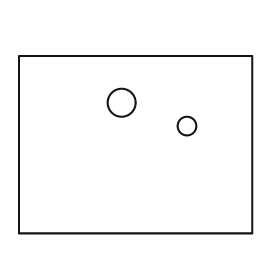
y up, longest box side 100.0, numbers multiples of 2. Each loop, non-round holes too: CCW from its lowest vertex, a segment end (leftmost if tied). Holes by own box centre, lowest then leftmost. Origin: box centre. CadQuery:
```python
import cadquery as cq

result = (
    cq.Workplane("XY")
    .moveTo(-50.0, -38.0)
    .lineTo(50.0, -38.0)
    .lineTo(50.0, 38.0)
    .lineTo(-50.0, 38.0)
    .close()
    .moveTo(22.0, 8.0)
    .circle(4.0)
    .moveTo(-6.0, 18.0)
    .circle(6.0)
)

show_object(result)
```